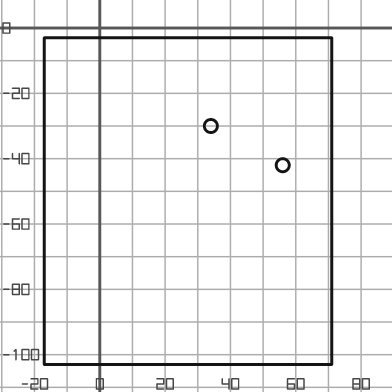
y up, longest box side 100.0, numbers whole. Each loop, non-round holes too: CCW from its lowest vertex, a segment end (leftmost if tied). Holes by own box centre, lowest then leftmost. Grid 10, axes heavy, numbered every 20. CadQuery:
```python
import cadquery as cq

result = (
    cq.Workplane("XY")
    .moveTo(-17.0, -103.0)
    .lineTo(71.0, -103.0)
    .lineTo(71.0, -3.0)
    .lineTo(-17.0, -3.0)
    .close()
    .moveTo(56.0, -42.0)
    .circle(2.0)
    .moveTo(34.0, -30.0)
    .circle(2.0)
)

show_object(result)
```